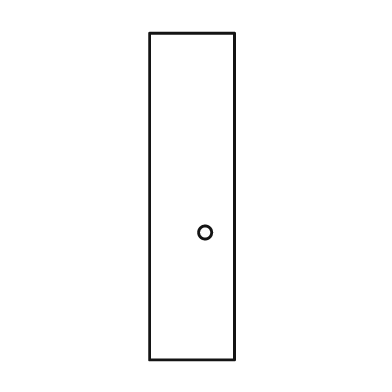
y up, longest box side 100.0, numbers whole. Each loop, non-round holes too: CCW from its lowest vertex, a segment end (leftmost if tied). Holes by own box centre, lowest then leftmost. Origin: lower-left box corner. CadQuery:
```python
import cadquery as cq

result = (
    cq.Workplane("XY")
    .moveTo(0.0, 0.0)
    .lineTo(26.0, 0.0)
    .lineTo(26.0, 100.0)
    .lineTo(0.0, 100.0)
    .close()
    .moveTo(17.0, 39.0)
    .circle(2.0)
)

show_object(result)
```